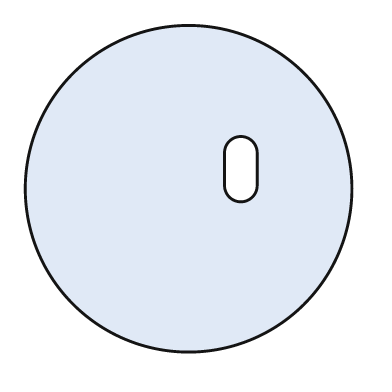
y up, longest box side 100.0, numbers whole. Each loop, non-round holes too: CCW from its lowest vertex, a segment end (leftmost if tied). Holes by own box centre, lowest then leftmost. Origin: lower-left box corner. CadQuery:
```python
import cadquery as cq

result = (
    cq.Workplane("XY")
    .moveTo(50.0, 50.0)
    .circle(50.0)
    .moveTo(61.0, 51.0)
    .threePointArc((66.0, 46.0), (71.0, 51.0))
    .lineTo(71.0, 61.0)
    .threePointArc((66.0, 66.0), (61.0, 61.0))
    .close()
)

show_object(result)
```